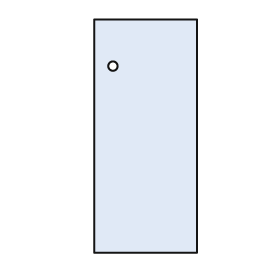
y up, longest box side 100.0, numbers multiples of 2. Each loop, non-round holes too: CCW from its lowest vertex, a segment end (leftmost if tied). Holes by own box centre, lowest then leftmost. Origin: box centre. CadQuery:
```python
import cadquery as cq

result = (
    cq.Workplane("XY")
    .moveTo(-22.0, -50.0)
    .lineTo(22.0, -50.0)
    .lineTo(22.0, 50.0)
    .lineTo(-22.0, 50.0)
    .close()
    .moveTo(-14.0, 30.0)
    .circle(2.0)
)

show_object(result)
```